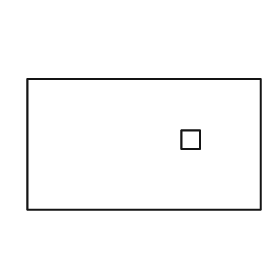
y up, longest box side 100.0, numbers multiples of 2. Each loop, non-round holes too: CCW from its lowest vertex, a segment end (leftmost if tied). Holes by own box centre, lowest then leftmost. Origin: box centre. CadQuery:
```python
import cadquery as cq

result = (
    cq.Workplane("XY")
    .moveTo(-50.0, -28.0)
    .lineTo(50.0, -28.0)
    .lineTo(50.0, 28.0)
    .lineTo(-50.0, 28.0)
    .close()
    .moveTo(16.0, -2.0)
    .lineTo(24.0, -2.0)
    .lineTo(24.0, 6.0)
    .lineTo(16.0, 6.0)
    .close()
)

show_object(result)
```